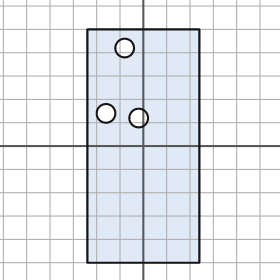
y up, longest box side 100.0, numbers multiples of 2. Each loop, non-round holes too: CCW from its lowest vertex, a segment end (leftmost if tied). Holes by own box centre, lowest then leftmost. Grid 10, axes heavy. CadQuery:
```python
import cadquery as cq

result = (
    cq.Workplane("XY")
    .moveTo(-24.0, -50.0)
    .lineTo(24.0, -50.0)
    .lineTo(24.0, 50.0)
    .lineTo(-24.0, 50.0)
    .close()
    .moveTo(-2.0, 12.0)
    .circle(4.0)
    .moveTo(-16.0, 14.0)
    .circle(4.0)
    .moveTo(-8.0, 42.0)
    .circle(4.0)
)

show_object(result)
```